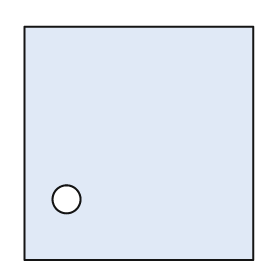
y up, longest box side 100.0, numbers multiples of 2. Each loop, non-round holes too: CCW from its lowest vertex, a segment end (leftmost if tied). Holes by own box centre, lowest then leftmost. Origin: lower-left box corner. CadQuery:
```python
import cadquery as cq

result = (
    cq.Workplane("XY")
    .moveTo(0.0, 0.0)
    .lineTo(98.0, 0.0)
    .lineTo(98.0, 100.0)
    .lineTo(0.0, 100.0)
    .close()
    .moveTo(18.0, 26.0)
    .circle(6.0)
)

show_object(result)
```